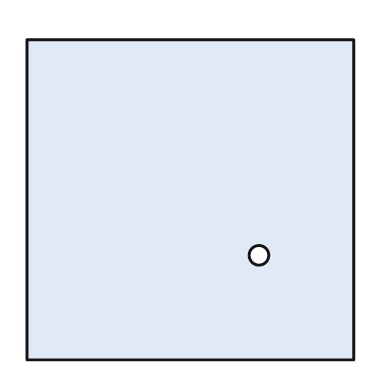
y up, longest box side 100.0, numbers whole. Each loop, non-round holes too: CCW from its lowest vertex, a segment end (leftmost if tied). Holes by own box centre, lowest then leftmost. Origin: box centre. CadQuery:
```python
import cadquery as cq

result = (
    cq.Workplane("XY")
    .moveTo(-50.0, -49.0)
    .lineTo(50.0, -49.0)
    .lineTo(50.0, 49.0)
    .lineTo(-50.0, 49.0)
    .close()
    .moveTo(21.0, -17.0)
    .circle(3.0)
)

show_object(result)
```